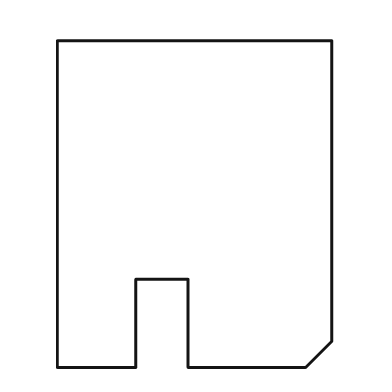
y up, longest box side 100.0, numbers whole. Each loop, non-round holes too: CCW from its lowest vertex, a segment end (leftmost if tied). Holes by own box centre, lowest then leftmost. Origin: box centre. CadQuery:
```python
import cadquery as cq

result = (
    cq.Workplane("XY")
    .moveTo(-42.0, -50.0)
    .lineTo(-18.0, -50.0)
    .lineTo(-18.0, -23.0)
    .lineTo(-2.0, -23.0)
    .lineTo(-2.0, -50.0)
    .lineTo(34.0, -50.0)
    .lineTo(42.0, -42.0)
    .lineTo(42.0, 50.0)
    .lineTo(-42.0, 50.0)
    .close()
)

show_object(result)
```